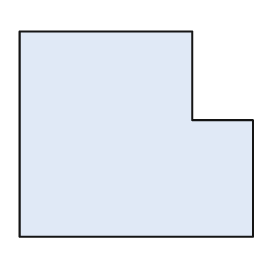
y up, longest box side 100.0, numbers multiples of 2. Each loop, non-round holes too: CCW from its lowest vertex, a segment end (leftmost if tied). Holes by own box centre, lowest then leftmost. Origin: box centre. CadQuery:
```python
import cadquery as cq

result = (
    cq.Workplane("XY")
    .moveTo(-50.0, -44.0)
    .lineTo(50.0, -44.0)
    .lineTo(50.0, 6.0)
    .lineTo(24.0, 6.0)
    .lineTo(24.0, 44.0)
    .lineTo(-50.0, 44.0)
    .close()
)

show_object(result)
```